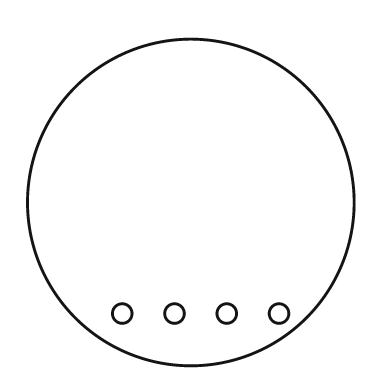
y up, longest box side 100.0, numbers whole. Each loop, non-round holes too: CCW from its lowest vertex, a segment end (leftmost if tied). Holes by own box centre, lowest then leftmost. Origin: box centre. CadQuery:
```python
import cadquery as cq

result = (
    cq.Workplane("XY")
    .moveTo(0.0, 0.0)
    .circle(50.0)
    .moveTo(-21.0, -34.0)
    .circle(3.0)
    .moveTo(-5.0, -34.0)
    .circle(3.0)
    .moveTo(11.0, -34.0)
    .circle(3.0)
    .moveTo(27.0, -34.0)
    .circle(3.0)
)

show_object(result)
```